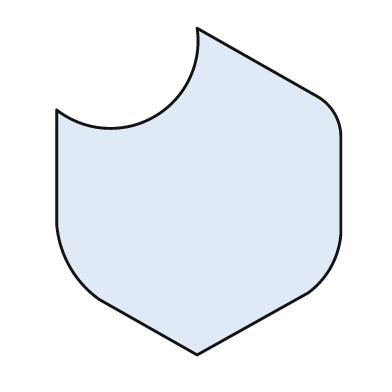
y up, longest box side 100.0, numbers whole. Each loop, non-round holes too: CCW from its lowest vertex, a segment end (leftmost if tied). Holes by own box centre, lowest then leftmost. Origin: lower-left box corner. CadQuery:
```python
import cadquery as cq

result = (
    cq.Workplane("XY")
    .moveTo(43.0, 0.0)
    .lineTo(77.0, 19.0)
    .threePointArc((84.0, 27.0), (87.0, 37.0))
    .lineTo(87.0, 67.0)
    .threePointArc((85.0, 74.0), (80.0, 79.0))
    .lineTo(43.0, 100.0)
    .threePointArc((30.0, 73.0), (0.0, 75.0))
    .lineTo(0.0, 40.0)
    .threePointArc((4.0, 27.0), (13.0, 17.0))
    .close()
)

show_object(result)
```